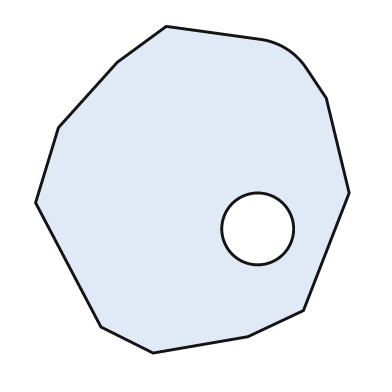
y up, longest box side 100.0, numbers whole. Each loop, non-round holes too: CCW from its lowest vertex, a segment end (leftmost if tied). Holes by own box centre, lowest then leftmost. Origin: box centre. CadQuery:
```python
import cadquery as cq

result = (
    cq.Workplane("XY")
    .moveTo(-12.0, -50.0)
    .lineTo(17.0, -45.0)
    .lineTo(34.0, -37.0)
    .lineTo(48.0, -1.0)
    .lineTo(41.0, 28.0)
    .lineTo(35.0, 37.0)
    .threePointArc((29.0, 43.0), (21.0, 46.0))
    .lineTo(-8.0, 50.0)
    .lineTo(-23.0, 39.0)
    .lineTo(-41.0, 19.0)
    .lineTo(-48.0, -4.0)
    .lineTo(-28.0, -42.0)
    .close()
    .moveTo(20.0, -12.0)
    .circle(11.0)
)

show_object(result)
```